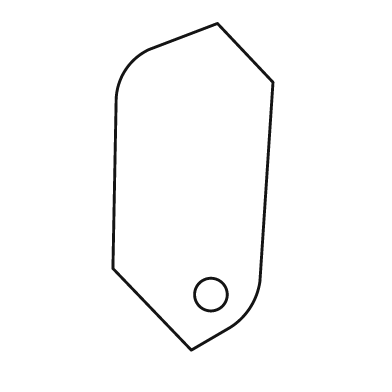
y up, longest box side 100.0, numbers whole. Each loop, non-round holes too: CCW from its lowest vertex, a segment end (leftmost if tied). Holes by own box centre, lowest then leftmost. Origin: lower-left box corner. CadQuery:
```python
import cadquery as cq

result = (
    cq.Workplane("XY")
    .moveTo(24.0, 0.0)
    .lineTo(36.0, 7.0)
    .threePointArc((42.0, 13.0), (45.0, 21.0))
    .lineTo(49.0, 82.0)
    .lineTo(32.0, 100.0)
    .lineTo(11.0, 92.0)
    .threePointArc((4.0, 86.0), (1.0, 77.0))
    .lineTo(0.0, 25.0)
    .close()
    .moveTo(30.0, 17.0)
    .circle(5.0)
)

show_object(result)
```